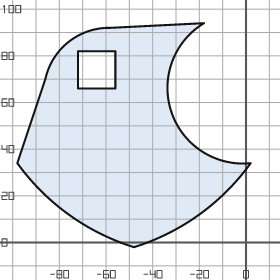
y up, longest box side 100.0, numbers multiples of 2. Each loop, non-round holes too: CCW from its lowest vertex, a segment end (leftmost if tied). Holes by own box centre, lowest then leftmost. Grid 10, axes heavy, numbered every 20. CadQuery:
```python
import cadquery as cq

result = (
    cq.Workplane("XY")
    .moveTo(-48.0, -2.0)
    .threePointArc((-20.0, 12.0), (2.0, 34.0))
    .threePointArc((-32.0, 56.0), (-18.0, 94.0))
    .lineTo(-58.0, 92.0)
    .threePointArc((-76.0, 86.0), (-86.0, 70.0))
    .lineTo(-98.0, 34.0)
    .threePointArc((-76.0, 12.0), (-48.0, -2.0))
    .close()
    .moveTo(-72.0, 66.0)
    .lineTo(-56.0, 66.0)
    .lineTo(-56.0, 82.0)
    .lineTo(-72.0, 82.0)
    .close()
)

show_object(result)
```